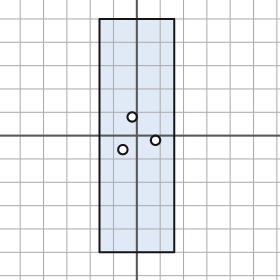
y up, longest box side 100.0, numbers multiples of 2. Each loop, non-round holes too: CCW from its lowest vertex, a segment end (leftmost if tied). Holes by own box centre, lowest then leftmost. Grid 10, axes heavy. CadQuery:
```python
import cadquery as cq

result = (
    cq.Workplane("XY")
    .moveTo(-16.0, -50.0)
    .lineTo(16.0, -50.0)
    .lineTo(16.0, 50.0)
    .lineTo(-16.0, 50.0)
    .close()
    .moveTo(-6.0, -6.0)
    .circle(2.0)
    .moveTo(8.0, -2.0)
    .circle(2.0)
    .moveTo(-2.0, 8.0)
    .circle(2.0)
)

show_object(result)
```